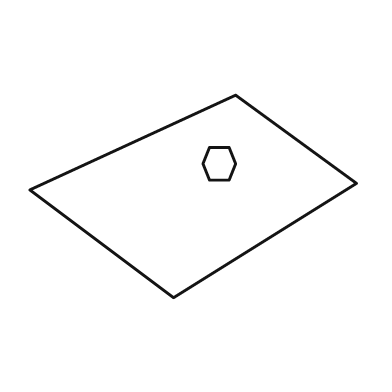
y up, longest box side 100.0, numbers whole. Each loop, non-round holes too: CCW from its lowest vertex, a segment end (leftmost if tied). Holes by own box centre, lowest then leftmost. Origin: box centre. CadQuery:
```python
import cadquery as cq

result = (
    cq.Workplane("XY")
    .moveTo(-6.0, -31.0)
    .lineTo(50.0, 4.0)
    .lineTo(13.0, 31.0)
    .lineTo(-50.0, 2.0)
    .close()
    .moveTo(5.0, 5.0)
    .lineTo(11.0, 5.0)
    .lineTo(13.0, 10.0)
    .lineTo(11.0, 15.0)
    .lineTo(5.0, 15.0)
    .lineTo(3.0, 10.0)
    .close()
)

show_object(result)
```